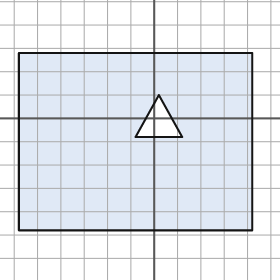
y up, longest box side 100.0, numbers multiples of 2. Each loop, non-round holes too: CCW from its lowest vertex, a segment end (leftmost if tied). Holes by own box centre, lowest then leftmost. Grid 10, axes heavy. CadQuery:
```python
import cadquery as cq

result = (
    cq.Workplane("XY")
    .moveTo(-58.0, -48.0)
    .lineTo(42.0, -48.0)
    .lineTo(42.0, 28.0)
    .lineTo(-58.0, 28.0)
    .close()
    .moveTo(-8.0, -8.0)
    .lineTo(12.0, -8.0)
    .lineTo(2.0, 10.0)
    .close()
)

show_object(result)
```